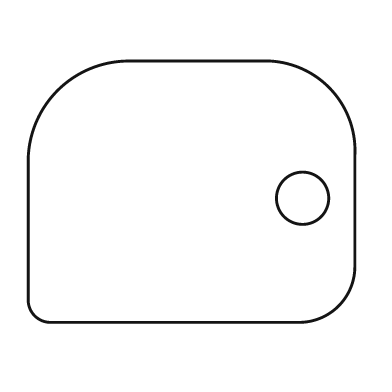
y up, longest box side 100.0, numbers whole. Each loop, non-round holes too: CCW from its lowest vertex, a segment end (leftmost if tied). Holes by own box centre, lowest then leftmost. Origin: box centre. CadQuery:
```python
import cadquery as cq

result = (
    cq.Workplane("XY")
    .moveTo(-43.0, -40.0)
    .lineTo(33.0, -40.0)
    .threePointArc((45.0, -35.0), (50.0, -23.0))
    .lineTo(50.0, 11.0)
    .threePointArc((42.0, 32.0), (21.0, 40.0))
    .lineTo(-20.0, 40.0)
    .threePointArc((-41.0, 31.0), (-50.0, 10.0))
    .lineTo(-50.0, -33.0)
    .threePointArc((-48.0, -38.0), (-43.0, -40.0))
    .close()
    .moveTo(34.0, -2.0)
    .circle(8.0)
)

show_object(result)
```